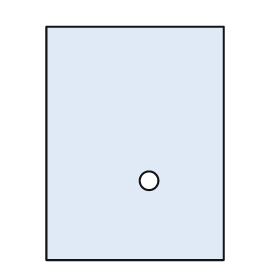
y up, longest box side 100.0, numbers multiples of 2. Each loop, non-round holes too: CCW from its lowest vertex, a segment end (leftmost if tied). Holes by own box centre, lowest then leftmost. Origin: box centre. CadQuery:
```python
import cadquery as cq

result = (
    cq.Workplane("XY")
    .moveTo(-38.0, -50.0)
    .lineTo(38.0, -50.0)
    .lineTo(38.0, 50.0)
    .lineTo(-38.0, 50.0)
    .close()
    .moveTo(6.0, -16.0)
    .circle(4.0)
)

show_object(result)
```